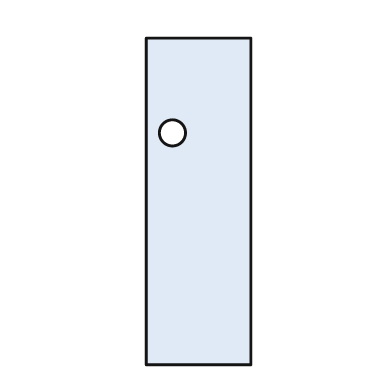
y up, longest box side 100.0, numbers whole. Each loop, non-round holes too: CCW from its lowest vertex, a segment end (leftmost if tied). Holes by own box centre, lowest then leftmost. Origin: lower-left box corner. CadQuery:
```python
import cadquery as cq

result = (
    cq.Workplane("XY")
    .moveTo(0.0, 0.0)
    .lineTo(32.0, 0.0)
    .lineTo(32.0, 100.0)
    .lineTo(0.0, 100.0)
    .close()
    .moveTo(8.0, 71.0)
    .circle(4.0)
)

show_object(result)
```